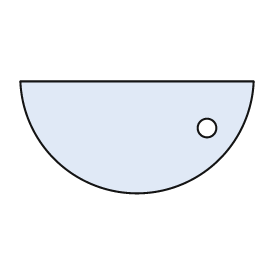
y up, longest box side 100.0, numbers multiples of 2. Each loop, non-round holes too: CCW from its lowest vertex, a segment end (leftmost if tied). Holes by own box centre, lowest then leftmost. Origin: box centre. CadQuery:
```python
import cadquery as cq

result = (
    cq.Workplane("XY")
    .moveTo(-50.0, 24.0)
    .threePointArc((0.0, -24.0), (50.0, 24.0))
    .close()
    .moveTo(30.0, 4.0)
    .circle(4.0)
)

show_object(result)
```